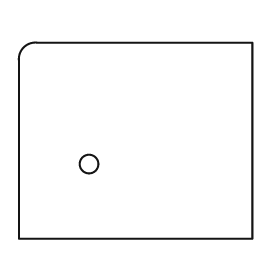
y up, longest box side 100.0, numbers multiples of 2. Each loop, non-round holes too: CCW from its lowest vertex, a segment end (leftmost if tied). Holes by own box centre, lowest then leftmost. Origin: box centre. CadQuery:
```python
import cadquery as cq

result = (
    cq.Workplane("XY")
    .moveTo(-50.0, -42.0)
    .lineTo(50.0, -42.0)
    .lineTo(50.0, 42.0)
    .lineTo(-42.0, 42.0)
    .threePointArc((-48.0, 40.0), (-50.0, 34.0))
    .close()
    .moveTo(-20.0, -10.0)
    .circle(4.0)
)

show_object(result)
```